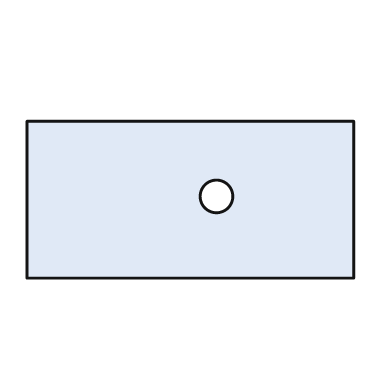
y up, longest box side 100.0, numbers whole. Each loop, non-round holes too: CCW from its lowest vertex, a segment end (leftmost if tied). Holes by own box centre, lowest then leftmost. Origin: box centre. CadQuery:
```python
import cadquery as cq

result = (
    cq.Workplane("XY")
    .moveTo(-50.0, -24.0)
    .lineTo(50.0, -24.0)
    .lineTo(50.0, 24.0)
    .lineTo(-50.0, 24.0)
    .close()
    .moveTo(8.0, 1.0)
    .circle(5.0)
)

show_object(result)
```